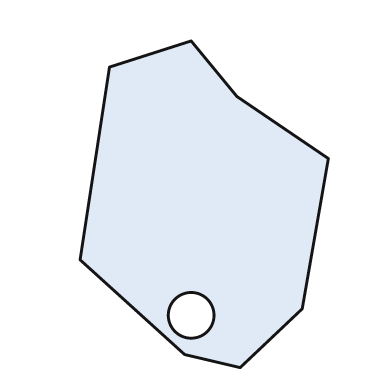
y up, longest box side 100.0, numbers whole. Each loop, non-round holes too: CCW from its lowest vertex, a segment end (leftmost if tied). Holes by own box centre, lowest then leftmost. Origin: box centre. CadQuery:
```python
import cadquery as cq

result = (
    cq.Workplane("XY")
    .moveTo(11.0, -50.0)
    .lineTo(30.0, -32.0)
    .lineTo(38.0, 14.0)
    .lineTo(10.0, 33.0)
    .lineTo(-4.0, 50.0)
    .lineTo(-29.0, 42.0)
    .lineTo(-38.0, -17.0)
    .lineTo(-6.0, -46.0)
    .close()
    .moveTo(-4.0, -34.0)
    .circle(7.0)
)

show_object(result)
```